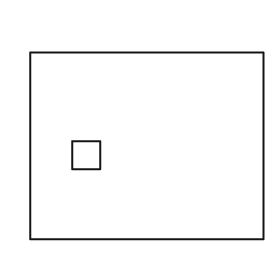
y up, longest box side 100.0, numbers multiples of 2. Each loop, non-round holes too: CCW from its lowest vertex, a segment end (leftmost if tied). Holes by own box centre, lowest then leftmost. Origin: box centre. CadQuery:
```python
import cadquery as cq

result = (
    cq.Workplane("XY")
    .moveTo(-50.0, -40.0)
    .lineTo(50.0, -40.0)
    .lineTo(50.0, 40.0)
    .lineTo(-50.0, 40.0)
    .close()
    .moveTo(-32.0, -10.0)
    .lineTo(-20.0, -10.0)
    .lineTo(-20.0, 2.0)
    .lineTo(-32.0, 2.0)
    .close()
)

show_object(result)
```